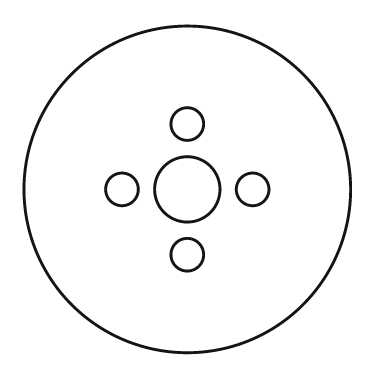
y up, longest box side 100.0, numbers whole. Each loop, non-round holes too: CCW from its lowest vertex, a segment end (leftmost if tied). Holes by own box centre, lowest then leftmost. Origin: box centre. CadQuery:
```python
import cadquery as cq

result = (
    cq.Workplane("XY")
    .moveTo(0.0, 0.0)
    .circle(50.0)
    .moveTo(0.0, -20.0)
    .circle(5.0)
    .moveTo(-20.0, 0.0)
    .circle(5.0)
    .moveTo(0.0, 0.0)
    .circle(10.0)
    .moveTo(20.0, 0.0)
    .circle(5.0)
    .moveTo(0.0, 20.0)
    .circle(5.0)
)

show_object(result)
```